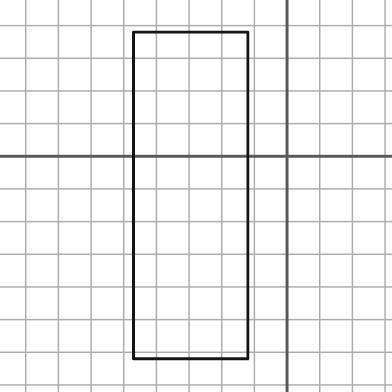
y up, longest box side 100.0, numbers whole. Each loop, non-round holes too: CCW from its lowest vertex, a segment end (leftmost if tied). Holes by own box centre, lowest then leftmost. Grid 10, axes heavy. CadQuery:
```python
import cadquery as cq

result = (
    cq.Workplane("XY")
    .moveTo(-47.0, -62.0)
    .lineTo(-12.0, -62.0)
    .lineTo(-12.0, 38.0)
    .lineTo(-47.0, 38.0)
    .close()
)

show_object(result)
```